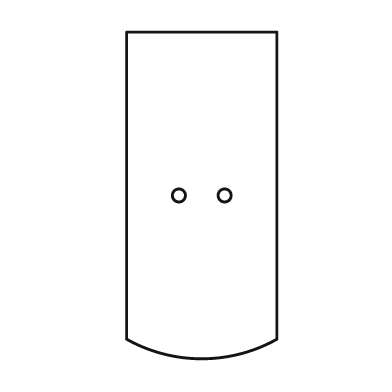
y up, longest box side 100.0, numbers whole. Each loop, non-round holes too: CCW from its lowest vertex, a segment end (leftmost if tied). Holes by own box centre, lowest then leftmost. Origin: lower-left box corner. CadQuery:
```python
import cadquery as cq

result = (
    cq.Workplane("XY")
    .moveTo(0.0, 6.0)
    .threePointArc((23.0, 0.0), (46.0, 6.0))
    .lineTo(46.0, 100.0)
    .lineTo(0.0, 100.0)
    .close()
    .moveTo(16.0, 50.0)
    .circle(2.0)
    .moveTo(30.0, 50.0)
    .circle(2.0)
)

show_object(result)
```